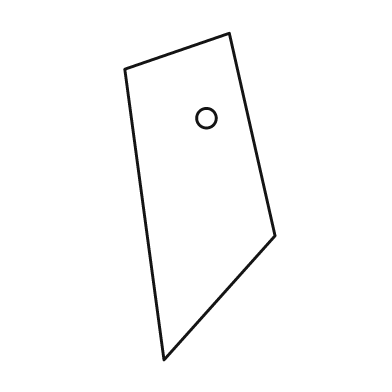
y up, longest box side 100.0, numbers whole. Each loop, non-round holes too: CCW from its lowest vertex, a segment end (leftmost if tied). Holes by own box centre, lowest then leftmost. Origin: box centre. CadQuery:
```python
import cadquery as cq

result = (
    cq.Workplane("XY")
    .moveTo(-11.0, -50.0)
    .lineTo(23.0, -12.0)
    .lineTo(9.0, 50.0)
    .lineTo(-23.0, 39.0)
    .close()
    .moveTo(2.0, 24.0)
    .circle(3.0)
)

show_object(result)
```